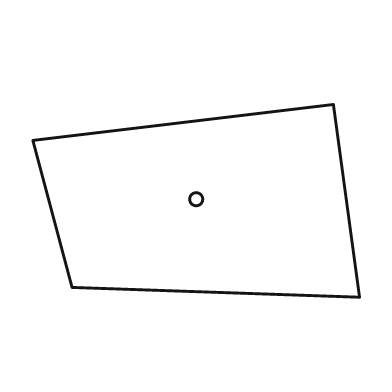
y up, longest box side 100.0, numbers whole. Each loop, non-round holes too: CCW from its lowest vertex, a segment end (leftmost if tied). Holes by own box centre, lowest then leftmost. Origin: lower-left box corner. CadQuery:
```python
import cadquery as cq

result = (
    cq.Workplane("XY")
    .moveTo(100.0, 0.0)
    .lineTo(92.0, 59.0)
    .lineTo(0.0, 48.0)
    .lineTo(12.0, 3.0)
    .close()
    .moveTo(50.0, 30.0)
    .circle(2.0)
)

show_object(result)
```